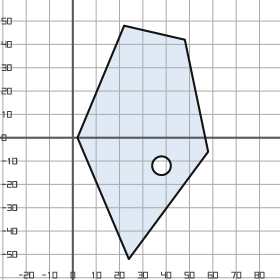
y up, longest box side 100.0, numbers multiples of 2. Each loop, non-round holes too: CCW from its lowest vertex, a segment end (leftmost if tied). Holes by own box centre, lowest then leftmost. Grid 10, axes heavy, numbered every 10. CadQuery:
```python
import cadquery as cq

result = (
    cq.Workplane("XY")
    .moveTo(24.0, -52.0)
    .lineTo(58.0, -6.0)
    .lineTo(48.0, 42.0)
    .lineTo(22.0, 48.0)
    .lineTo(2.0, 0.0)
    .close()
    .moveTo(38.0, -12.0)
    .circle(4.0)
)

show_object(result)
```